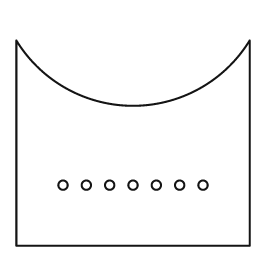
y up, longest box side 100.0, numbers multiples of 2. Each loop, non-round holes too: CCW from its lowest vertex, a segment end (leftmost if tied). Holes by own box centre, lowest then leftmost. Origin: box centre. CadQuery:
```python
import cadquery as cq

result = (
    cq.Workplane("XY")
    .moveTo(-50.0, -44.0)
    .lineTo(50.0, -44.0)
    .lineTo(50.0, 44.0)
    .threePointArc((0.0, 16.0), (-50.0, 44.0))
    .close()
    .moveTo(-30.0, -18.0)
    .circle(2.0)
    .moveTo(-20.0, -18.0)
    .circle(2.0)
    .moveTo(-10.0, -18.0)
    .circle(2.0)
    .moveTo(0.0, -18.0)
    .circle(2.0)
    .moveTo(10.0, -18.0)
    .circle(2.0)
    .moveTo(20.0, -18.0)
    .circle(2.0)
    .moveTo(30.0, -18.0)
    .circle(2.0)
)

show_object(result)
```